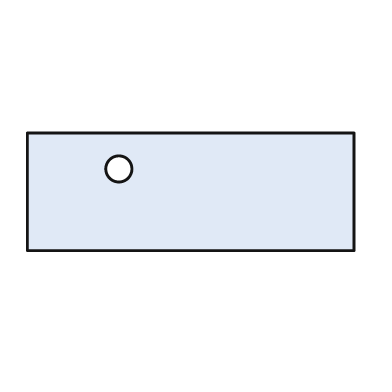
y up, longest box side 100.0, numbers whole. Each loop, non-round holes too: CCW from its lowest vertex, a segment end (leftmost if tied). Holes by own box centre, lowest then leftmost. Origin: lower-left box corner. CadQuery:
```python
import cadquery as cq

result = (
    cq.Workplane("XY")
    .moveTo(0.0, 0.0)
    .lineTo(100.0, 0.0)
    .lineTo(100.0, 36.0)
    .lineTo(0.0, 36.0)
    .close()
    .moveTo(28.0, 25.0)
    .circle(4.0)
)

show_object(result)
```